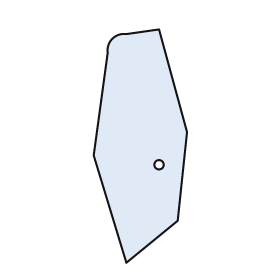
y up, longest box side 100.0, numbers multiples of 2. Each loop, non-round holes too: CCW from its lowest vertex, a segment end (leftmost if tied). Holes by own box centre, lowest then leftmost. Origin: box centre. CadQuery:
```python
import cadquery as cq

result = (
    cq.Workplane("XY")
    .moveTo(-6.0, -50.0)
    .lineTo(16.0, -32.0)
    .lineTo(20.0, 6.0)
    .lineTo(8.0, 50.0)
    .lineTo(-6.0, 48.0)
    .threePointArc((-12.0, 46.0), (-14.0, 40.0))
    .lineTo(-20.0, -4.0)
    .close()
    .moveTo(8.0, -8.0)
    .circle(2.0)
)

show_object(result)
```